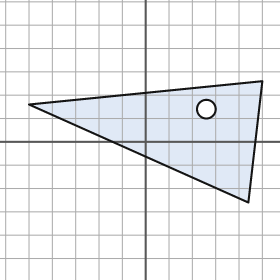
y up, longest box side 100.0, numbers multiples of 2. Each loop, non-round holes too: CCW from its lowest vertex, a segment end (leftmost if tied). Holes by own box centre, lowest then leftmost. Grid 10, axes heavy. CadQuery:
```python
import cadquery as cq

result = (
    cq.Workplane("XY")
    .moveTo(44.0, -26.0)
    .lineTo(50.0, 26.0)
    .lineTo(-50.0, 16.0)
    .close()
    .moveTo(26.0, 14.0)
    .circle(4.0)
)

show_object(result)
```